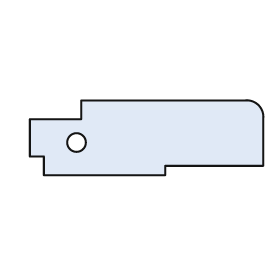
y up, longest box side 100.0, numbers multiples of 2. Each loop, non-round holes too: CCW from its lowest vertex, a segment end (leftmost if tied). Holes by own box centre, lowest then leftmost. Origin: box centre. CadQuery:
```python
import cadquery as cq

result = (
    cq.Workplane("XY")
    .moveTo(-44.0, -16.0)
    .lineTo(8.0, -16.0)
    .lineTo(8.0, -12.0)
    .lineTo(50.0, -12.0)
    .lineTo(50.0, 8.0)
    .threePointArc((48.0, 14.0), (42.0, 16.0))
    .lineTo(-28.0, 16.0)
    .lineTo(-28.0, 8.0)
    .lineTo(-50.0, 8.0)
    .lineTo(-50.0, -8.0)
    .lineTo(-44.0, -8.0)
    .close()
    .moveTo(-30.0, -2.0)
    .circle(4.0)
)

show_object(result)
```